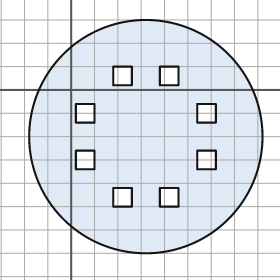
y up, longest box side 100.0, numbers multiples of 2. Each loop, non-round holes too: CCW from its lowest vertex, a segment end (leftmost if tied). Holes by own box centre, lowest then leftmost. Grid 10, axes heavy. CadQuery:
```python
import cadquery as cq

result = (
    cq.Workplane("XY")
    .moveTo(32.0, -20.0)
    .circle(50.0)
    .moveTo(18.0, -50.0)
    .lineTo(26.0, -50.0)
    .lineTo(26.0, -42.0)
    .lineTo(18.0, -42.0)
    .close()
    .moveTo(38.0, -50.0)
    .lineTo(46.0, -50.0)
    .lineTo(46.0, -42.0)
    .lineTo(38.0, -42.0)
    .close()
    .moveTo(2.0, -34.0)
    .lineTo(10.0, -34.0)
    .lineTo(10.0, -26.0)
    .lineTo(2.0, -26.0)
    .close()
    .moveTo(54.0, -34.0)
    .lineTo(62.0, -34.0)
    .lineTo(62.0, -26.0)
    .lineTo(54.0, -26.0)
    .close()
    .moveTo(2.0, -14.0)
    .lineTo(10.0, -14.0)
    .lineTo(10.0, -6.0)
    .lineTo(2.0, -6.0)
    .close()
    .moveTo(54.0, -14.0)
    .lineTo(62.0, -14.0)
    .lineTo(62.0, -6.0)
    .lineTo(54.0, -6.0)
    .close()
    .moveTo(18.0, 2.0)
    .lineTo(26.0, 2.0)
    .lineTo(26.0, 10.0)
    .lineTo(18.0, 10.0)
    .close()
    .moveTo(38.0, 2.0)
    .lineTo(46.0, 2.0)
    .lineTo(46.0, 10.0)
    .lineTo(38.0, 10.0)
    .close()
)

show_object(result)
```